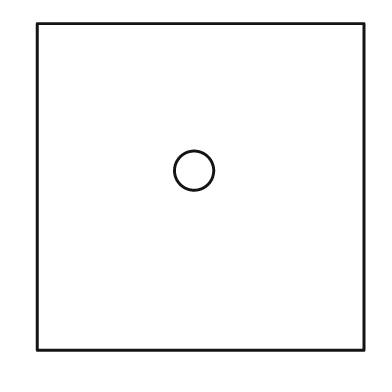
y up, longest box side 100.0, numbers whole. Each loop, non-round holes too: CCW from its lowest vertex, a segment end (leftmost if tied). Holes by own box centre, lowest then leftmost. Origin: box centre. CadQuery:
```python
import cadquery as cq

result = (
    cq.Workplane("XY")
    .moveTo(-50.0, -50.0)
    .lineTo(50.0, -50.0)
    .lineTo(50.0, 50.0)
    .lineTo(-50.0, 50.0)
    .close()
    .moveTo(-2.0, 5.0)
    .circle(6.0)
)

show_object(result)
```